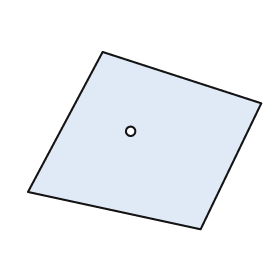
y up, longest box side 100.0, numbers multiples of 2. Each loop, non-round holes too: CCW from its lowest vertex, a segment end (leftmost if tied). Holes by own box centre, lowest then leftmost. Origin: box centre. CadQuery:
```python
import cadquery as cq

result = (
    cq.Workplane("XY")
    .moveTo(24.0, -38.0)
    .lineTo(50.0, 16.0)
    .lineTo(-18.0, 38.0)
    .lineTo(-50.0, -22.0)
    .close()
    .moveTo(-6.0, 4.0)
    .circle(2.0)
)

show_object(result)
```